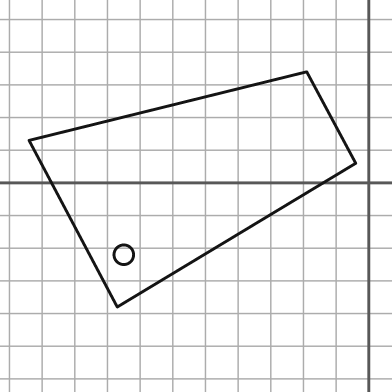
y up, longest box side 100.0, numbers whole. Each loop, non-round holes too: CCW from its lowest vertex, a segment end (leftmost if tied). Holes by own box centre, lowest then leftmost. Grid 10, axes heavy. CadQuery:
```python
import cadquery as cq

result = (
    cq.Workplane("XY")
    .moveTo(-77.0, -38.0)
    .lineTo(-4.0, 6.0)
    .lineTo(-19.0, 34.0)
    .lineTo(-104.0, 13.0)
    .close()
    .moveTo(-75.0, -22.0)
    .circle(3.0)
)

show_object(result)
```